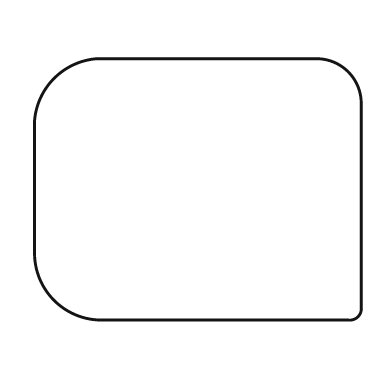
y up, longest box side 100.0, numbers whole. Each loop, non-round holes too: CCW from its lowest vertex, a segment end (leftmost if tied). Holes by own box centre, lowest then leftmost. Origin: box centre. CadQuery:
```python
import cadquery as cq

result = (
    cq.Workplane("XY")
    .moveTo(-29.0, -40.0)
    .lineTo(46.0, -40.0)
    .threePointArc((49.0, -39.0), (50.0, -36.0))
    .lineTo(50.0, 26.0)
    .threePointArc((46.0, 36.0), (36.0, 40.0))
    .lineTo(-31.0, 40.0)
    .threePointArc((-44.0, 34.0), (-50.0, 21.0))
    .lineTo(-50.0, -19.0)
    .threePointArc((-44.0, -34.0), (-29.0, -40.0))
    .close()
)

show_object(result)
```